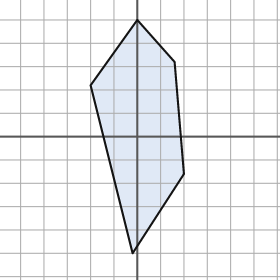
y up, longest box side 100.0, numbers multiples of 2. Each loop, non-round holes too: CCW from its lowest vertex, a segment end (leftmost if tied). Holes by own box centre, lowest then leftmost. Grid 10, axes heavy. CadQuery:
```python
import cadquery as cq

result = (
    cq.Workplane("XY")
    .moveTo(-2.0, -50.0)
    .lineTo(20.0, -16.0)
    .lineTo(16.0, 32.0)
    .lineTo(0.0, 50.0)
    .lineTo(-20.0, 22.0)
    .close()
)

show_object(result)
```